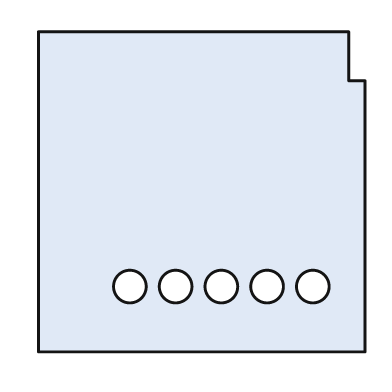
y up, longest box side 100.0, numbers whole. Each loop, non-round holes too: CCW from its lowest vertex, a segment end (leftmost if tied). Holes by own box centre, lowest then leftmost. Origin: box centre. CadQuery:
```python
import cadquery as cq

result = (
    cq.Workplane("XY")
    .moveTo(-50.0, -49.0)
    .lineTo(50.0, -49.0)
    .lineTo(50.0, 34.0)
    .lineTo(45.0, 34.0)
    .lineTo(45.0, 49.0)
    .lineTo(-50.0, 49.0)
    .close()
    .moveTo(-22.0, -29.0)
    .circle(5.0)
    .moveTo(-8.0, -29.0)
    .circle(5.0)
    .moveTo(6.0, -29.0)
    .circle(5.0)
    .moveTo(20.0, -29.0)
    .circle(5.0)
    .moveTo(34.0, -29.0)
    .circle(5.0)
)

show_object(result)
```